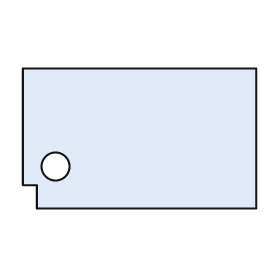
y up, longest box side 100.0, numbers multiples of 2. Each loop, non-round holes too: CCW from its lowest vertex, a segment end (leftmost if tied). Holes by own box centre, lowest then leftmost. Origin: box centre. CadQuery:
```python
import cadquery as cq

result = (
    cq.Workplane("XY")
    .moveTo(-44.0, -30.0)
    .lineTo(50.0, -30.0)
    .lineTo(50.0, 30.0)
    .lineTo(-50.0, 30.0)
    .lineTo(-50.0, -20.0)
    .lineTo(-44.0, -20.0)
    .close()
    .moveTo(-36.0, -12.0)
    .circle(6.0)
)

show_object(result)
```